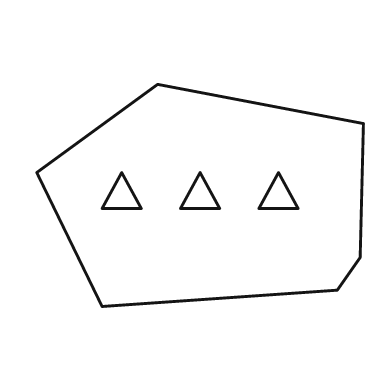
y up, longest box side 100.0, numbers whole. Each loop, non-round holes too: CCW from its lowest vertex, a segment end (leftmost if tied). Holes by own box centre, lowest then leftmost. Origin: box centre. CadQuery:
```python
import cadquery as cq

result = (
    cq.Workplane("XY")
    .moveTo(-30.0, -34.0)
    .lineTo(42.0, -29.0)
    .lineTo(49.0, -19.0)
    .lineTo(50.0, 22.0)
    .lineTo(-13.0, 34.0)
    .lineTo(-50.0, 7.0)
    .close()
    .moveTo(-30.0, -4.0)
    .lineTo(-18.0, -4.0)
    .lineTo(-24.0, 7.0)
    .close()
    .moveTo(-6.0, -4.0)
    .lineTo(6.0, -4.0)
    .lineTo(0.0, 7.0)
    .close()
    .moveTo(18.0, -4.0)
    .lineTo(30.0, -4.0)
    .lineTo(24.0, 7.0)
    .close()
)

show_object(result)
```